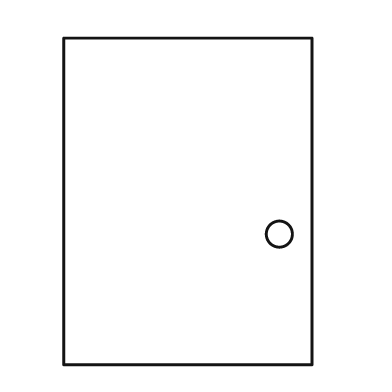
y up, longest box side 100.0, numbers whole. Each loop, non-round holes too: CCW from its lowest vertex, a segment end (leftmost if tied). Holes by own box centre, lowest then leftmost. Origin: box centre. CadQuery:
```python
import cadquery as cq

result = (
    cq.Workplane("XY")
    .moveTo(-38.0, -50.0)
    .lineTo(38.0, -50.0)
    .lineTo(38.0, 50.0)
    .lineTo(-38.0, 50.0)
    .close()
    .moveTo(28.0, -10.0)
    .circle(4.0)
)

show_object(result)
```